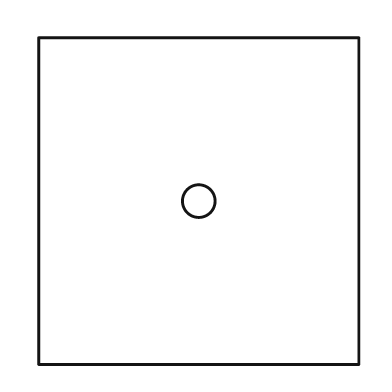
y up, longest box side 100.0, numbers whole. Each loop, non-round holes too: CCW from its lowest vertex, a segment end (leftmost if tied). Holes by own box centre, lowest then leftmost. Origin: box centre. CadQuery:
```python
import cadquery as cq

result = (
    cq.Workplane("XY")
    .moveTo(-49.0, -50.0)
    .lineTo(49.0, -50.0)
    .lineTo(49.0, 50.0)
    .lineTo(-49.0, 50.0)
    .close()
    .moveTo(0.0, 0.0)
    .circle(5.0)
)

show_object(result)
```